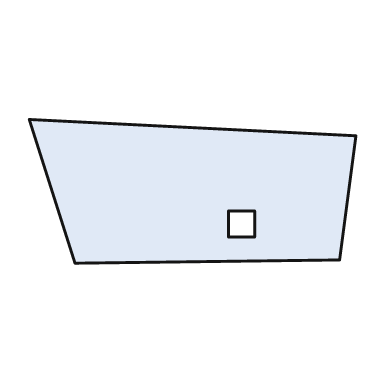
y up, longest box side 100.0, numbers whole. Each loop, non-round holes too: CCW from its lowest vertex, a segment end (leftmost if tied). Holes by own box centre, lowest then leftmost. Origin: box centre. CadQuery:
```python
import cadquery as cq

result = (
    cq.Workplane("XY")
    .moveTo(-36.0, -22.0)
    .lineTo(45.0, -21.0)
    .lineTo(50.0, 17.0)
    .lineTo(-50.0, 22.0)
    .close()
    .moveTo(11.0, -14.0)
    .lineTo(19.0, -14.0)
    .lineTo(19.0, -6.0)
    .lineTo(11.0, -6.0)
    .close()
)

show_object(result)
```